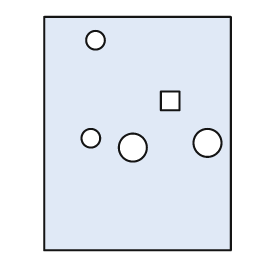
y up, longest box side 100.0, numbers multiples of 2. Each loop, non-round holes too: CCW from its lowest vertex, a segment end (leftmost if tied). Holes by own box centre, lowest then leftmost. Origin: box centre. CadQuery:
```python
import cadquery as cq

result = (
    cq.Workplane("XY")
    .moveTo(-40.0, -50.0)
    .lineTo(40.0, -50.0)
    .lineTo(40.0, 50.0)
    .lineTo(-40.0, 50.0)
    .close()
    .moveTo(-2.0, -6.0)
    .circle(6.0)
    .moveTo(30.0, -4.0)
    .circle(6.0)
    .moveTo(-20.0, -2.0)
    .circle(4.0)
    .moveTo(10.0, 10.0)
    .lineTo(18.0, 10.0)
    .lineTo(18.0, 18.0)
    .lineTo(10.0, 18.0)
    .close()
    .moveTo(-18.0, 40.0)
    .circle(4.0)
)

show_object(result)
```